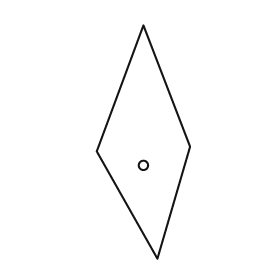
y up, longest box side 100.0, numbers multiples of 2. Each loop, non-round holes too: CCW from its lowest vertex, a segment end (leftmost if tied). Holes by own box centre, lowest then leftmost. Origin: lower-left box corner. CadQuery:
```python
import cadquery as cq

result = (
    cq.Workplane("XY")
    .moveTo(26.0, 0.0)
    .lineTo(40.0, 48.0)
    .lineTo(20.0, 100.0)
    .lineTo(0.0, 46.0)
    .close()
    .moveTo(20.0, 40.0)
    .circle(2.0)
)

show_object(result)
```